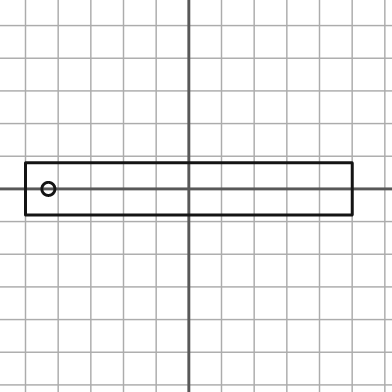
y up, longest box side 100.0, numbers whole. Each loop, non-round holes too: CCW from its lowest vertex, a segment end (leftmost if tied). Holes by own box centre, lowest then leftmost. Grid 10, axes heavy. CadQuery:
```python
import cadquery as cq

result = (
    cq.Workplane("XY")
    .moveTo(-50.0, -8.0)
    .lineTo(50.0, -8.0)
    .lineTo(50.0, 8.0)
    .lineTo(-50.0, 8.0)
    .close()
    .moveTo(-43.0, 0.0)
    .circle(2.0)
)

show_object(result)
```